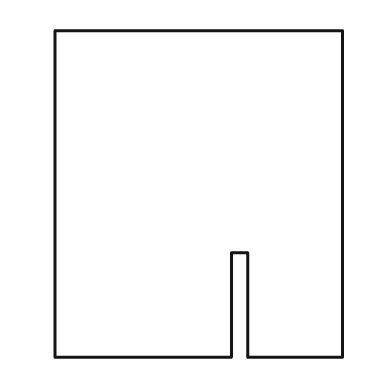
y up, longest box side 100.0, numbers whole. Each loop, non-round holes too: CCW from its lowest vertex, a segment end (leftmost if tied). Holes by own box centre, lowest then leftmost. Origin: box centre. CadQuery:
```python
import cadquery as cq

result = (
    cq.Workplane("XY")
    .moveTo(-44.0, -50.0)
    .lineTo(10.0, -50.0)
    .lineTo(10.0, -18.0)
    .lineTo(15.0, -18.0)
    .lineTo(15.0, -50.0)
    .lineTo(44.0, -50.0)
    .lineTo(44.0, 50.0)
    .lineTo(-44.0, 50.0)
    .close()
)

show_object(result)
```